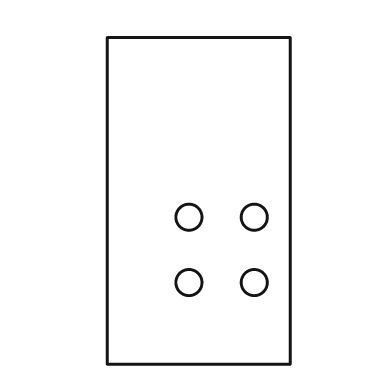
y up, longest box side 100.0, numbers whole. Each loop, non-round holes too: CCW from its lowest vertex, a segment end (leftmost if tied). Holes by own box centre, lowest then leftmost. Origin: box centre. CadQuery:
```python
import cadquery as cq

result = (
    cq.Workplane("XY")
    .moveTo(-28.0, -50.0)
    .lineTo(28.0, -50.0)
    .lineTo(28.0, 50.0)
    .lineTo(-28.0, 50.0)
    .close()
    .moveTo(-3.0, -25.0)
    .circle(4.0)
    .moveTo(17.0, -25.0)
    .circle(4.0)
    .moveTo(-3.0, -5.0)
    .circle(4.0)
    .moveTo(17.0, -5.0)
    .circle(4.0)
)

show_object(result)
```